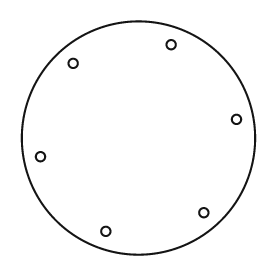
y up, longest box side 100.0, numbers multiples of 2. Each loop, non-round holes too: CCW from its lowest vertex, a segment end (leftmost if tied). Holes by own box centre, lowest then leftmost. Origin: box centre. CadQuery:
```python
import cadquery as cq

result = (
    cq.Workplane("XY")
    .moveTo(0.0, 0.0)
    .circle(50.0)
    .moveTo(-14.0, -40.0)
    .circle(2.0)
    .moveTo(28.0, -32.0)
    .circle(2.0)
    .moveTo(-42.0, -8.0)
    .circle(2.0)
    .moveTo(42.0, 8.0)
    .circle(2.0)
    .moveTo(-28.0, 32.0)
    .circle(2.0)
    .moveTo(14.0, 40.0)
    .circle(2.0)
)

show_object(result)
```